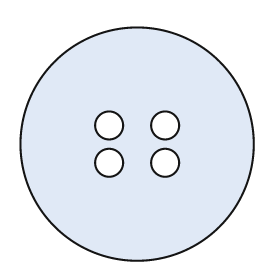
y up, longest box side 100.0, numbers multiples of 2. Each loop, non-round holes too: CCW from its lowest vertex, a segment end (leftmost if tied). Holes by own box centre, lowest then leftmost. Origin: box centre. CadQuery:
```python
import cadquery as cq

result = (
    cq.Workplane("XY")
    .moveTo(0.0, 0.0)
    .circle(50.0)
    .moveTo(-12.0, -8.0)
    .circle(6.0)
    .moveTo(12.0, -8.0)
    .circle(6.0)
    .moveTo(-12.0, 8.0)
    .circle(6.0)
    .moveTo(12.0, 8.0)
    .circle(6.0)
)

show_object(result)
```